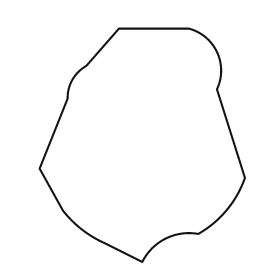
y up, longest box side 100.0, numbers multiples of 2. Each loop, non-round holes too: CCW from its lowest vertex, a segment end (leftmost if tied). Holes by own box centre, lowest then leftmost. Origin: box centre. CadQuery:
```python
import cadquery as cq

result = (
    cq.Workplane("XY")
    .moveTo(0.0, -50.0)
    .threePointArc((10.0, -40.0), (24.0, -38.0))
    .threePointArc((36.0, -28.0), (44.0, -14.0))
    .lineTo(32.0, 24.0)
    .threePointArc((32.0, 40.0), (20.0, 50.0))
    .lineTo(-10.0, 50.0)
    .lineTo(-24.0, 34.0)
    .threePointArc((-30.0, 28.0), (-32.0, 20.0))
    .lineTo(-44.0, -10.0)
    .lineTo(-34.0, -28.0)
    .threePointArc((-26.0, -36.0), (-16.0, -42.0))
    .close()
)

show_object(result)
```